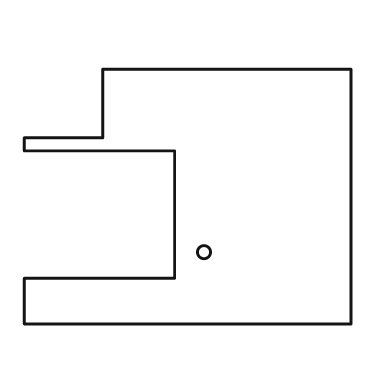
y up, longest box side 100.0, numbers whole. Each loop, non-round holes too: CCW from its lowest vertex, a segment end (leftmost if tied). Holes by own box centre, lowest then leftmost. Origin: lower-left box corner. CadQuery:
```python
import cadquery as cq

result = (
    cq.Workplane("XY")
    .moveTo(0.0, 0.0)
    .lineTo(100.0, 0.0)
    .lineTo(100.0, 78.0)
    .lineTo(24.0, 78.0)
    .lineTo(24.0, 57.0)
    .lineTo(0.0, 57.0)
    .lineTo(0.0, 53.0)
    .lineTo(46.0, 53.0)
    .lineTo(46.0, 14.0)
    .lineTo(0.0, 14.0)
    .close()
    .moveTo(55.0, 22.0)
    .circle(2.0)
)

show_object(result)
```